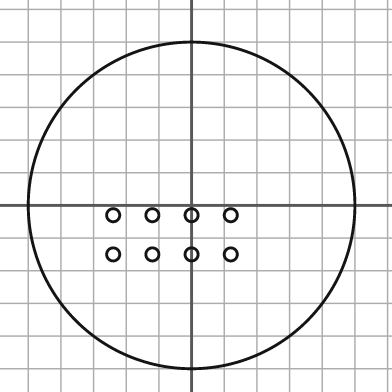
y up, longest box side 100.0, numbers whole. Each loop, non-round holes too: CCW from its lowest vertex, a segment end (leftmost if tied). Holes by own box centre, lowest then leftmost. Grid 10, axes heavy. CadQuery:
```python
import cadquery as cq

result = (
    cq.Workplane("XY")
    .moveTo(0.0, 0.0)
    .circle(50.0)
    .moveTo(-24.0, -15.0)
    .circle(2.0)
    .moveTo(-12.0, -15.0)
    .circle(2.0)
    .moveTo(0.0, -15.0)
    .circle(2.0)
    .moveTo(12.0, -15.0)
    .circle(2.0)
    .moveTo(-24.0, -3.0)
    .circle(2.0)
    .moveTo(-12.0, -3.0)
    .circle(2.0)
    .moveTo(0.0, -3.0)
    .circle(2.0)
    .moveTo(12.0, -3.0)
    .circle(2.0)
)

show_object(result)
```